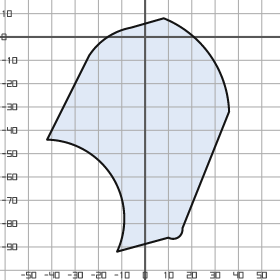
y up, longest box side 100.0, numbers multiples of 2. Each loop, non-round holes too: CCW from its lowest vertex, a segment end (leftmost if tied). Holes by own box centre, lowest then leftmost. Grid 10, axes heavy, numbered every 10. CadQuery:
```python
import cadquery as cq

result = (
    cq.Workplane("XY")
    .moveTo(-12.0, -92.0)
    .lineTo(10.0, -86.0)
    .threePointArc((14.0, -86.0), (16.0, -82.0))
    .lineTo(36.0, -32.0)
    .threePointArc((28.0, -8.0), (8.0, 8.0))
    .lineTo(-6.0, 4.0)
    .threePointArc((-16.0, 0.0), (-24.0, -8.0))
    .lineTo(-42.0, -44.0)
    .threePointArc((-14.0, -60.0), (-12.0, -92.0))
    .close()
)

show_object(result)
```